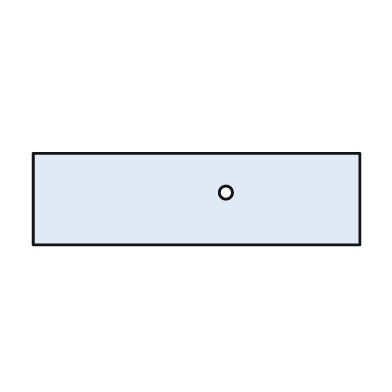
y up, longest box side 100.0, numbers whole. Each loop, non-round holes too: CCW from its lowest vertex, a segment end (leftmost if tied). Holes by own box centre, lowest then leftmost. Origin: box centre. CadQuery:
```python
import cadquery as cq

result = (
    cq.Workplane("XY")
    .moveTo(-50.0, -14.0)
    .lineTo(50.0, -14.0)
    .lineTo(50.0, 14.0)
    .lineTo(-50.0, 14.0)
    .close()
    .moveTo(9.0, 2.0)
    .circle(2.0)
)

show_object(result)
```